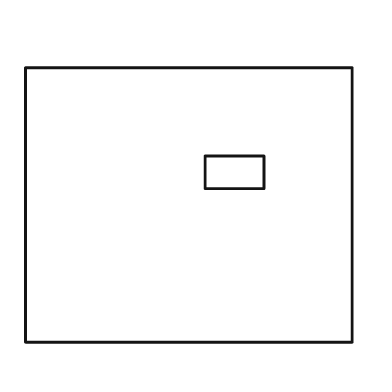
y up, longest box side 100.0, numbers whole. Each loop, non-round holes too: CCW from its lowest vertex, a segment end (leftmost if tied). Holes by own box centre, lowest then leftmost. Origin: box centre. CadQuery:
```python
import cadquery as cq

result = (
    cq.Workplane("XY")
    .moveTo(-50.0, -42.0)
    .lineTo(50.0, -42.0)
    .lineTo(50.0, 42.0)
    .lineTo(-50.0, 42.0)
    .close()
    .moveTo(5.0, 5.0)
    .lineTo(23.0, 5.0)
    .lineTo(23.0, 15.0)
    .lineTo(5.0, 15.0)
    .close()
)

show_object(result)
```